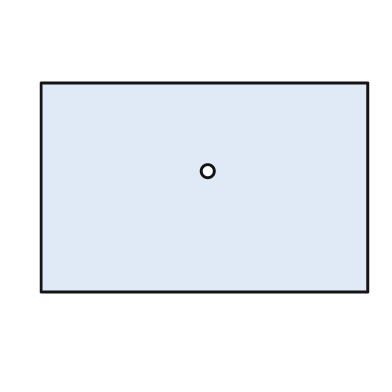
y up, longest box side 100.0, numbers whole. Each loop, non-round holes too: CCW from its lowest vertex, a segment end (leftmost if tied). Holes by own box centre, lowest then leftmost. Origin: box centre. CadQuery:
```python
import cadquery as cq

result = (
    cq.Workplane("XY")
    .moveTo(-50.0, -32.0)
    .lineTo(50.0, -32.0)
    .lineTo(50.0, 32.0)
    .lineTo(-50.0, 32.0)
    .close()
    .moveTo(1.0, 5.0)
    .circle(2.0)
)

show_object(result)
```